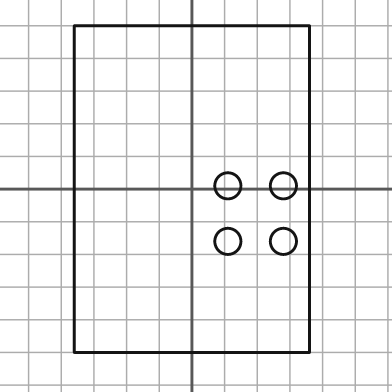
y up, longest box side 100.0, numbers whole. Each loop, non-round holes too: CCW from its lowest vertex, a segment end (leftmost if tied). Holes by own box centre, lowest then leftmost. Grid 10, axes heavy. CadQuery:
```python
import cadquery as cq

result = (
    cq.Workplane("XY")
    .moveTo(-36.0, -50.0)
    .lineTo(36.0, -50.0)
    .lineTo(36.0, 50.0)
    .lineTo(-36.0, 50.0)
    .close()
    .moveTo(11.0, -16.0)
    .circle(4.0)
    .moveTo(28.0, -16.0)
    .circle(4.0)
    .moveTo(11.0, 1.0)
    .circle(4.0)
    .moveTo(28.0, 1.0)
    .circle(4.0)
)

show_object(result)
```